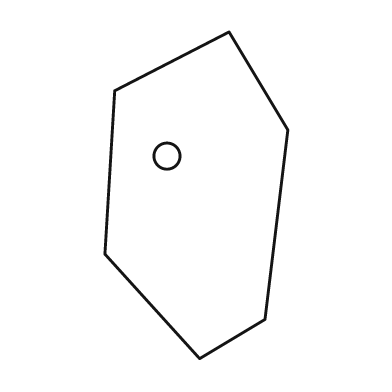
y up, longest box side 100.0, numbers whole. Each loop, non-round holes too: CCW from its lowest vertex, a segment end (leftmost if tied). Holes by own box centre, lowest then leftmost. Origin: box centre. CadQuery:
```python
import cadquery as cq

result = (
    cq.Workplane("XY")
    .moveTo(1.0, -50.0)
    .lineTo(21.0, -38.0)
    .lineTo(28.0, 20.0)
    .lineTo(10.0, 50.0)
    .lineTo(-25.0, 32.0)
    .lineTo(-28.0, -18.0)
    .close()
    .moveTo(-9.0, 12.0)
    .circle(4.0)
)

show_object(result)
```